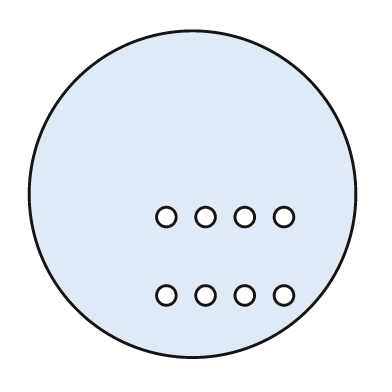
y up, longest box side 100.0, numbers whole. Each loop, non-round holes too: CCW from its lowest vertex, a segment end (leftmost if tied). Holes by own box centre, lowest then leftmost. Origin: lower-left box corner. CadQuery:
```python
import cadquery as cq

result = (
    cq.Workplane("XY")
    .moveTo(50.0, 50.0)
    .circle(50.0)
    .moveTo(42.0, 19.0)
    .circle(3.0)
    .moveTo(54.0, 19.0)
    .circle(3.0)
    .moveTo(66.0, 19.0)
    .circle(3.0)
    .moveTo(78.0, 19.0)
    .circle(3.0)
    .moveTo(42.0, 43.0)
    .circle(3.0)
    .moveTo(54.0, 43.0)
    .circle(3.0)
    .moveTo(66.0, 43.0)
    .circle(3.0)
    .moveTo(78.0, 43.0)
    .circle(3.0)
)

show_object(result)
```